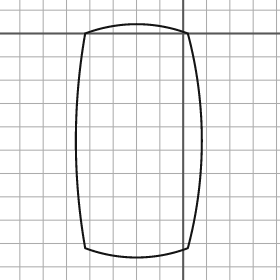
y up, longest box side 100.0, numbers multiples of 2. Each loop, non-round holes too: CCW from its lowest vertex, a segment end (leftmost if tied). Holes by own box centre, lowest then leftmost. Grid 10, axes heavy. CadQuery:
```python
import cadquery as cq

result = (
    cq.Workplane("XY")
    .moveTo(-42.0, -92.0)
    .threePointArc((-20.0, -96.0), (2.0, -92.0))
    .threePointArc((8.0, -46.0), (2.0, 0.0))
    .threePointArc((-20.0, 4.0), (-42.0, 0.0))
    .threePointArc((-46.0, -46.0), (-42.0, -92.0))
    .close()
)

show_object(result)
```